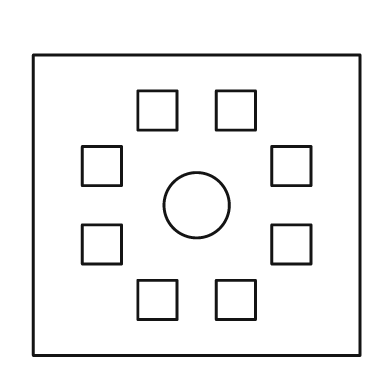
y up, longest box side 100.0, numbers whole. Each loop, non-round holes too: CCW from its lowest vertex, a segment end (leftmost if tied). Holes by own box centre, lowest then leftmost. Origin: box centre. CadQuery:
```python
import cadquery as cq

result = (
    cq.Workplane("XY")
    .moveTo(-50.0, -46.0)
    .lineTo(50.0, -46.0)
    .lineTo(50.0, 46.0)
    .lineTo(-50.0, 46.0)
    .close()
    .moveTo(-18.0, -35.0)
    .lineTo(-6.0, -35.0)
    .lineTo(-6.0, -23.0)
    .lineTo(-18.0, -23.0)
    .close()
    .moveTo(6.0, -35.0)
    .lineTo(18.0, -35.0)
    .lineTo(18.0, -23.0)
    .lineTo(6.0, -23.0)
    .close()
    .moveTo(-35.0, -18.0)
    .lineTo(-23.0, -18.0)
    .lineTo(-23.0, -6.0)
    .lineTo(-35.0, -6.0)
    .close()
    .moveTo(23.0, -18.0)
    .lineTo(35.0, -18.0)
    .lineTo(35.0, -6.0)
    .lineTo(23.0, -6.0)
    .close()
    .moveTo(0.0, 0.0)
    .circle(10.0)
    .moveTo(-35.0, 6.0)
    .lineTo(-23.0, 6.0)
    .lineTo(-23.0, 18.0)
    .lineTo(-35.0, 18.0)
    .close()
    .moveTo(23.0, 6.0)
    .lineTo(35.0, 6.0)
    .lineTo(35.0, 18.0)
    .lineTo(23.0, 18.0)
    .close()
    .moveTo(-18.0, 23.0)
    .lineTo(-6.0, 23.0)
    .lineTo(-6.0, 35.0)
    .lineTo(-18.0, 35.0)
    .close()
    .moveTo(6.0, 23.0)
    .lineTo(18.0, 23.0)
    .lineTo(18.0, 35.0)
    .lineTo(6.0, 35.0)
    .close()
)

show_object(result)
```